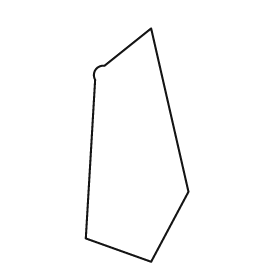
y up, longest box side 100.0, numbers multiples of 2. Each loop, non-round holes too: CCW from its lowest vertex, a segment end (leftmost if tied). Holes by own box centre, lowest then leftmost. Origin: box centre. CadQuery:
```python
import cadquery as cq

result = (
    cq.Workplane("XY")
    .moveTo(6.0, -50.0)
    .lineTo(22.0, -20.0)
    .lineTo(6.0, 50.0)
    .lineTo(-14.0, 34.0)
    .threePointArc((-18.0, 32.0), (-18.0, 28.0))
    .lineTo(-22.0, -40.0)
    .close()
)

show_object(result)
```